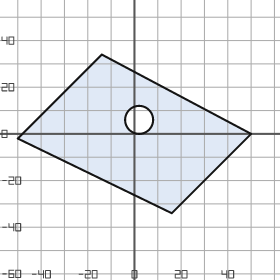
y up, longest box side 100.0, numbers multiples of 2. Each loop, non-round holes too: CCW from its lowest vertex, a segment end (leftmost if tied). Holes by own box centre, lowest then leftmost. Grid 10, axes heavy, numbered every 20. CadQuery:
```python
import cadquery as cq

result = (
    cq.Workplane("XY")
    .moveTo(16.0, -34.0)
    .lineTo(50.0, 0.0)
    .lineTo(-14.0, 34.0)
    .lineTo(-50.0, -2.0)
    .close()
    .moveTo(2.0, 6.0)
    .circle(6.0)
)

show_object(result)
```